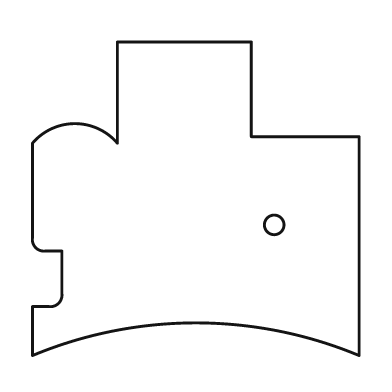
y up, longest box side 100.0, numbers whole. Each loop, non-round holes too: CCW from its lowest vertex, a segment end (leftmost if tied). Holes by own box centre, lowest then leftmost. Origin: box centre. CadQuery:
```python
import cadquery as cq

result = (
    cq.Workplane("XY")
    .moveTo(-50.0, -48.0)
    .threePointArc((0.0, -38.0), (50.0, -48.0))
    .lineTo(50.0, 19.0)
    .lineTo(17.0, 19.0)
    .lineTo(17.0, 48.0)
    .lineTo(-24.0, 48.0)
    .lineTo(-24.0, 17.0)
    .threePointArc((-37.0, 23.0), (-50.0, 17.0))
    .lineTo(-50.0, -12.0)
    .threePointArc((-49.0, -15.0), (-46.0, -16.0))
    .lineTo(-41.0, -16.0)
    .lineTo(-41.0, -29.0)
    .threePointArc((-42.0, -32.0), (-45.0, -33.0))
    .lineTo(-50.0, -33.0)
    .close()
    .moveTo(24.0, -8.0)
    .circle(3.0)
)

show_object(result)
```